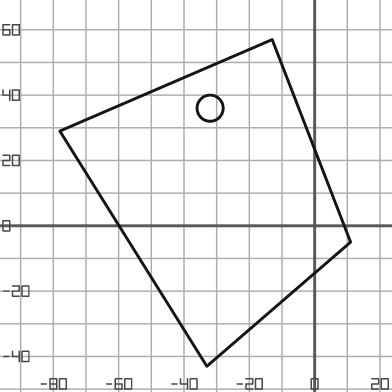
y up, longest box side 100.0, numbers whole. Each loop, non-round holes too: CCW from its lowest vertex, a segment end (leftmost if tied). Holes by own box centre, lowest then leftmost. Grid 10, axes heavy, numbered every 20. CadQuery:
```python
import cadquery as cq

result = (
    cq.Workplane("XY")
    .moveTo(-33.0, -43.0)
    .lineTo(11.0, -5.0)
    .lineTo(-13.0, 57.0)
    .lineTo(-78.0, 29.0)
    .close()
    .moveTo(-32.0, 36.0)
    .circle(4.0)
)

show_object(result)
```